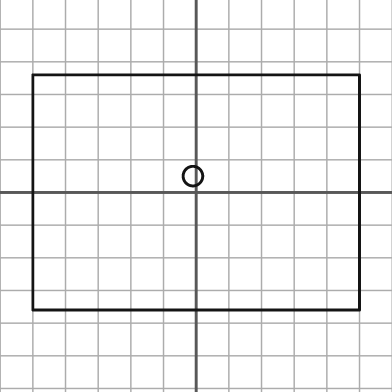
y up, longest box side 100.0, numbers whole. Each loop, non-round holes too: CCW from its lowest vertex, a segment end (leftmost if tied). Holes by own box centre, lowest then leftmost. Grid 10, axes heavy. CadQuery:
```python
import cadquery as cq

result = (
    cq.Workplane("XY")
    .moveTo(-50.0, -36.0)
    .lineTo(50.0, -36.0)
    .lineTo(50.0, 36.0)
    .lineTo(-50.0, 36.0)
    .close()
    .moveTo(-1.0, 5.0)
    .circle(3.0)
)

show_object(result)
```